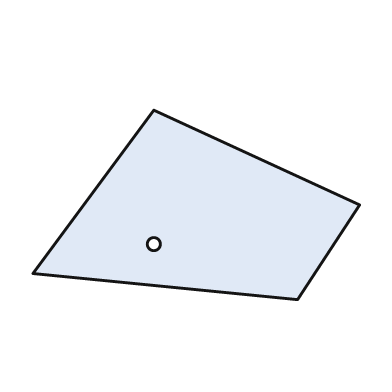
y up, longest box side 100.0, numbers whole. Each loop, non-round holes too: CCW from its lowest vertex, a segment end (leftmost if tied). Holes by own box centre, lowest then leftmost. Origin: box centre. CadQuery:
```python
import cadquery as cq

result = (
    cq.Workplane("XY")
    .moveTo(31.0, -29.0)
    .lineTo(50.0, 0.0)
    .lineTo(-13.0, 29.0)
    .lineTo(-50.0, -21.0)
    .close()
    .moveTo(-13.0, -12.0)
    .circle(2.0)
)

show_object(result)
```